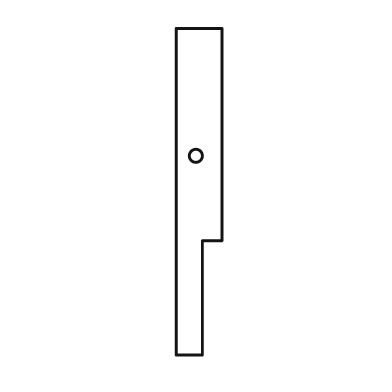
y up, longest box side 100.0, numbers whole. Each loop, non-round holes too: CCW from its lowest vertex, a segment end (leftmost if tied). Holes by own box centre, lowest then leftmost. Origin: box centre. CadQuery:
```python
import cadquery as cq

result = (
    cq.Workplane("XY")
    .moveTo(-7.0, -50.0)
    .lineTo(1.0, -50.0)
    .lineTo(1.0, -15.0)
    .lineTo(7.0, -15.0)
    .lineTo(7.0, 50.0)
    .lineTo(-7.0, 50.0)
    .close()
    .moveTo(-1.0, 11.0)
    .circle(2.0)
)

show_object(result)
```